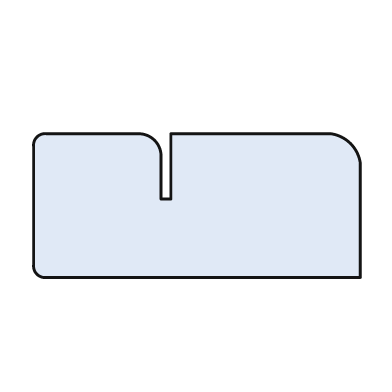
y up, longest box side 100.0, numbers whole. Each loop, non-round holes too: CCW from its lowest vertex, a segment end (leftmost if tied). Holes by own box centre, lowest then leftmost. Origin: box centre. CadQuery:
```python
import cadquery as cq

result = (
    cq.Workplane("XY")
    .moveTo(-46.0, -22.0)
    .lineTo(50.0, -22.0)
    .lineTo(50.0, 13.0)
    .threePointArc((47.0, 19.0), (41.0, 22.0))
    .lineTo(-8.0, 22.0)
    .lineTo(-8.0, 2.0)
    .lineTo(-11.0, 2.0)
    .lineTo(-11.0, 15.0)
    .threePointArc((-13.0, 20.0), (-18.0, 22.0))
    .lineTo(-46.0, 22.0)
    .threePointArc((-49.0, 21.0), (-50.0, 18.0))
    .lineTo(-50.0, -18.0)
    .threePointArc((-49.0, -21.0), (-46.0, -22.0))
    .close()
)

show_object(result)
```